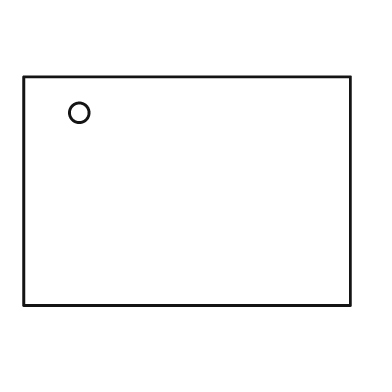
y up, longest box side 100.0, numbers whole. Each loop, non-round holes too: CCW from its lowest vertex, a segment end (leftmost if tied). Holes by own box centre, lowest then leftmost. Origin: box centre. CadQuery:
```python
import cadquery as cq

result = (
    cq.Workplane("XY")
    .moveTo(-50.0, -35.0)
    .lineTo(50.0, -35.0)
    .lineTo(50.0, 35.0)
    .lineTo(-50.0, 35.0)
    .close()
    .moveTo(-33.0, 24.0)
    .circle(3.0)
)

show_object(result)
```